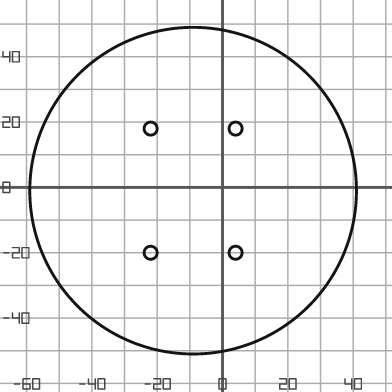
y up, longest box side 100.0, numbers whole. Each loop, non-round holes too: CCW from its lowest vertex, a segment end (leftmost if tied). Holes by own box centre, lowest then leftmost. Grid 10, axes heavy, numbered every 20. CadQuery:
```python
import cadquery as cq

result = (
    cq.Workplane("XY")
    .moveTo(-9.0, -1.0)
    .circle(50.0)
    .moveTo(-22.0, -20.0)
    .circle(2.0)
    .moveTo(4.0, -20.0)
    .circle(2.0)
    .moveTo(-22.0, 18.0)
    .circle(2.0)
    .moveTo(4.0, 18.0)
    .circle(2.0)
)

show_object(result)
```